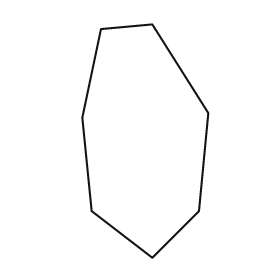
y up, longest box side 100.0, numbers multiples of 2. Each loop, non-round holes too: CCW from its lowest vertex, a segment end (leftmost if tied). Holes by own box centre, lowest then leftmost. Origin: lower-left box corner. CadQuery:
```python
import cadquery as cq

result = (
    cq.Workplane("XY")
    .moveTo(30.0, 0.0)
    .lineTo(50.0, 20.0)
    .lineTo(54.0, 62.0)
    .lineTo(30.0, 100.0)
    .lineTo(8.0, 98.0)
    .lineTo(0.0, 60.0)
    .lineTo(4.0, 20.0)
    .close()
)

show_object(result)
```